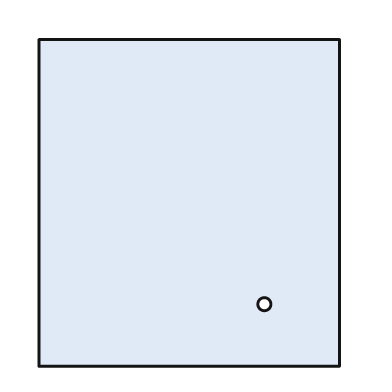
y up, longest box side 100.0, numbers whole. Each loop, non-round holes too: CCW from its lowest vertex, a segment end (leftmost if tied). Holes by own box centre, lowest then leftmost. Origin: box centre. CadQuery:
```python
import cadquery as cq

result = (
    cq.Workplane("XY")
    .moveTo(-46.0, -50.0)
    .lineTo(46.0, -50.0)
    .lineTo(46.0, 50.0)
    .lineTo(-46.0, 50.0)
    .close()
    .moveTo(23.0, -31.0)
    .circle(2.0)
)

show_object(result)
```